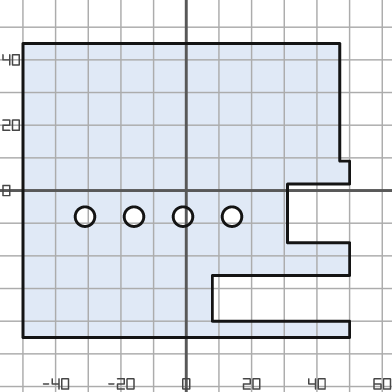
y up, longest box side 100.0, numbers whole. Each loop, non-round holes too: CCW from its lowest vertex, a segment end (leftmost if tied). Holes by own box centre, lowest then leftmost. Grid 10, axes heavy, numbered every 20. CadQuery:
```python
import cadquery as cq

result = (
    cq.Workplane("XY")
    .moveTo(-50.0, -45.0)
    .lineTo(50.0, -45.0)
    .lineTo(50.0, -40.0)
    .lineTo(8.0, -40.0)
    .lineTo(8.0, -26.0)
    .lineTo(50.0, -26.0)
    .lineTo(50.0, -16.0)
    .lineTo(31.0, -16.0)
    .lineTo(31.0, 2.0)
    .lineTo(50.0, 2.0)
    .lineTo(50.0, 9.0)
    .lineTo(47.0, 9.0)
    .lineTo(47.0, 45.0)
    .lineTo(-50.0, 45.0)
    .close()
    .moveTo(-31.0, -8.0)
    .circle(3.0)
    .moveTo(-16.0, -8.0)
    .circle(3.0)
    .moveTo(-1.0, -8.0)
    .circle(3.0)
    .moveTo(14.0, -8.0)
    .circle(3.0)
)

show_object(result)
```